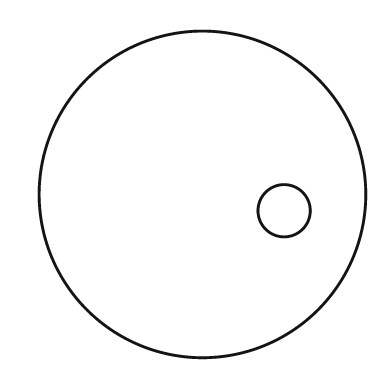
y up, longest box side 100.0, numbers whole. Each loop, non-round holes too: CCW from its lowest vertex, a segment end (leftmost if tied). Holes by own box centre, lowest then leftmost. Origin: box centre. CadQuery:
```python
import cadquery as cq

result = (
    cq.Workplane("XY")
    .moveTo(0.0, 0.0)
    .circle(50.0)
    .moveTo(25.0, -5.0)
    .circle(8.0)
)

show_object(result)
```